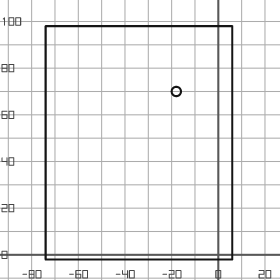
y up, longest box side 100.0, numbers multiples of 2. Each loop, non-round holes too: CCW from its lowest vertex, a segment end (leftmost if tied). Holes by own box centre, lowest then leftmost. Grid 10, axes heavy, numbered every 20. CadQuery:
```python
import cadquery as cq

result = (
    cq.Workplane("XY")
    .moveTo(-74.0, -2.0)
    .lineTo(6.0, -2.0)
    .lineTo(6.0, 98.0)
    .lineTo(-74.0, 98.0)
    .close()
    .moveTo(-18.0, 70.0)
    .circle(2.0)
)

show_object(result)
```